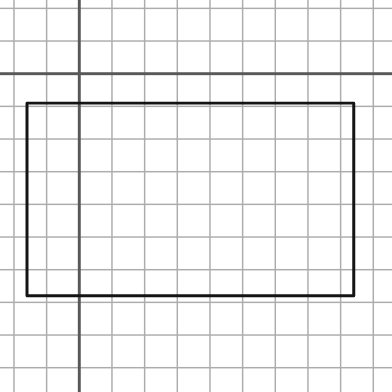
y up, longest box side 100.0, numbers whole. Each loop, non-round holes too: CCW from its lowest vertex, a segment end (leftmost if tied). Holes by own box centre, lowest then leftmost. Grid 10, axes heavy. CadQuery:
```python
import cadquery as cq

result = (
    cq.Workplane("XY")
    .moveTo(-16.0, -68.0)
    .lineTo(84.0, -68.0)
    .lineTo(84.0, -9.0)
    .lineTo(-16.0, -9.0)
    .close()
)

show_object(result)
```